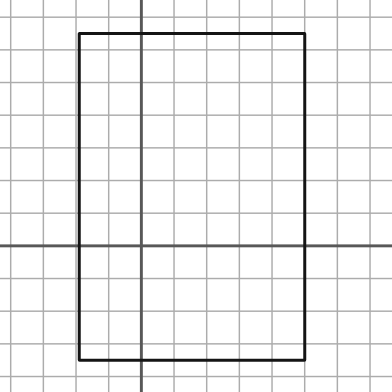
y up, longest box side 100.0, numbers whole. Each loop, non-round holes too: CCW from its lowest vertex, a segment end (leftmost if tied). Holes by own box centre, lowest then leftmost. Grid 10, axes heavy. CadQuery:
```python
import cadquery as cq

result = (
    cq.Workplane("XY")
    .moveTo(-19.0, -35.0)
    .lineTo(50.0, -35.0)
    .lineTo(50.0, 65.0)
    .lineTo(-19.0, 65.0)
    .close()
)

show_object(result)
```